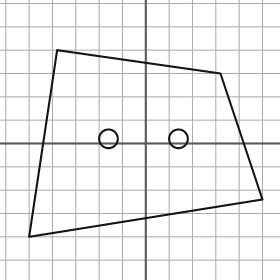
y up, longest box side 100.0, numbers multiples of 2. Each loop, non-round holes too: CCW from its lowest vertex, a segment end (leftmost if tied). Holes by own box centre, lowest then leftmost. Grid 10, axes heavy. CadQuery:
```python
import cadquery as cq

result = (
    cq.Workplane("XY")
    .moveTo(-50.0, -40.0)
    .lineTo(50.0, -24.0)
    .lineTo(32.0, 30.0)
    .lineTo(-38.0, 40.0)
    .close()
    .moveTo(-16.0, 2.0)
    .circle(4.0)
    .moveTo(14.0, 2.0)
    .circle(4.0)
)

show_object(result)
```